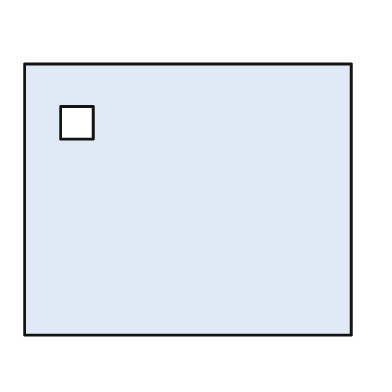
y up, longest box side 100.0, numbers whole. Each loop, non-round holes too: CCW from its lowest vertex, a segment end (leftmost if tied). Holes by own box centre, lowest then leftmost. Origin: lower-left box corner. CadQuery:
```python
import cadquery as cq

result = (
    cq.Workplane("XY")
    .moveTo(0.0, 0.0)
    .lineTo(100.0, 0.0)
    .lineTo(100.0, 83.0)
    .lineTo(0.0, 83.0)
    .close()
    .moveTo(11.0, 60.0)
    .lineTo(21.0, 60.0)
    .lineTo(21.0, 70.0)
    .lineTo(11.0, 70.0)
    .close()
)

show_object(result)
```